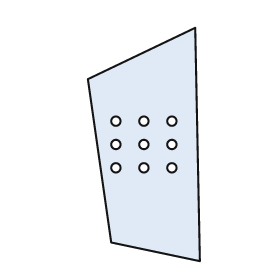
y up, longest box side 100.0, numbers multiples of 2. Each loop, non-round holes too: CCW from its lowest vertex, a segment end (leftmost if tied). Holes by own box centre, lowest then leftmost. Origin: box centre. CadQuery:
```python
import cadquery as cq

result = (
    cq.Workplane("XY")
    .moveTo(24.0, -50.0)
    .lineTo(22.0, 50.0)
    .lineTo(-24.0, 28.0)
    .lineTo(-14.0, -42.0)
    .close()
    .moveTo(-12.0, -10.0)
    .circle(2.0)
    .moveTo(0.0, -10.0)
    .circle(2.0)
    .moveTo(12.0, -10.0)
    .circle(2.0)
    .moveTo(-12.0, 0.0)
    .circle(2.0)
    .moveTo(0.0, 0.0)
    .circle(2.0)
    .moveTo(12.0, 0.0)
    .circle(2.0)
    .moveTo(-12.0, 10.0)
    .circle(2.0)
    .moveTo(0.0, 10.0)
    .circle(2.0)
    .moveTo(12.0, 10.0)
    .circle(2.0)
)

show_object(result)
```